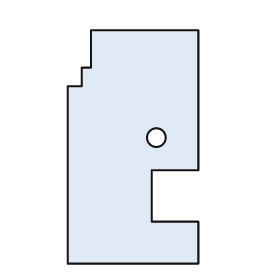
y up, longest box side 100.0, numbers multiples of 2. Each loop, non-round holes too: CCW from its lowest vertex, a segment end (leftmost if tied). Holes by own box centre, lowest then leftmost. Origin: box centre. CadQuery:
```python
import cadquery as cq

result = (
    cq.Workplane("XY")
    .moveTo(-28.0, -50.0)
    .lineTo(28.0, -50.0)
    .lineTo(28.0, -32.0)
    .lineTo(8.0, -32.0)
    .lineTo(8.0, -10.0)
    .lineTo(28.0, -10.0)
    .lineTo(28.0, 50.0)
    .lineTo(-18.0, 50.0)
    .lineTo(-18.0, 34.0)
    .lineTo(-22.0, 34.0)
    .lineTo(-22.0, 26.0)
    .lineTo(-28.0, 26.0)
    .close()
    .moveTo(10.0, 4.0)
    .circle(4.0)
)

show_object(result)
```